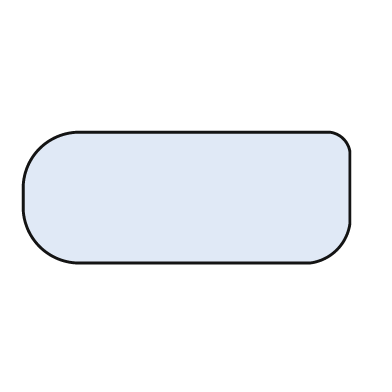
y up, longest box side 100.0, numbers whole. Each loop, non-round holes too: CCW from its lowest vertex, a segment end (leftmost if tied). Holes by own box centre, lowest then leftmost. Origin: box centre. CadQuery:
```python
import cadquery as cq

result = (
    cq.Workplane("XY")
    .moveTo(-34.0, -20.0)
    .lineTo(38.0, -20.0)
    .threePointArc((46.0, -16.0), (50.0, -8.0))
    .lineTo(50.0, 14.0)
    .threePointArc((48.0, 18.0), (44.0, 20.0))
    .lineTo(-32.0, 20.0)
    .threePointArc((-45.0, 15.0), (-50.0, 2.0))
    .lineTo(-50.0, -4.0)
    .threePointArc((-45.0, -15.0), (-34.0, -20.0))
    .close()
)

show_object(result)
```